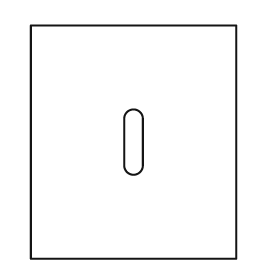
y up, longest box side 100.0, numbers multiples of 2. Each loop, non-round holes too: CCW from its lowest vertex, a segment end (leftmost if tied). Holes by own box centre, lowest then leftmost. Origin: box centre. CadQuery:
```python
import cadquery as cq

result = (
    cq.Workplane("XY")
    .moveTo(-44.0, -50.0)
    .lineTo(44.0, -50.0)
    .lineTo(44.0, 50.0)
    .lineTo(-44.0, 50.0)
    .close()
    .moveTo(-4.0, -10.0)
    .threePointArc((0.0, -14.0), (4.0, -10.0))
    .lineTo(4.0, 10.0)
    .threePointArc((0.0, 14.0), (-4.0, 10.0))
    .close()
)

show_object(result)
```